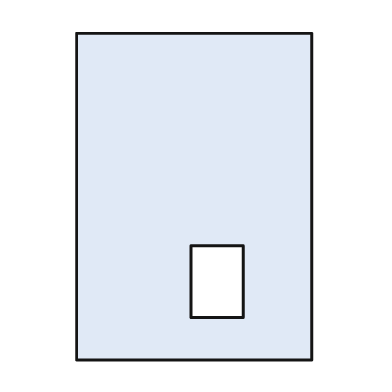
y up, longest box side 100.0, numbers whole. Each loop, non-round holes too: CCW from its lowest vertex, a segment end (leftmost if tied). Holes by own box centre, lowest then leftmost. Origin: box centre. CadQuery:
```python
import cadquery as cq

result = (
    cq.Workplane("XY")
    .moveTo(-36.0, -50.0)
    .lineTo(36.0, -50.0)
    .lineTo(36.0, 50.0)
    .lineTo(-36.0, 50.0)
    .close()
    .moveTo(-1.0, -37.0)
    .lineTo(15.0, -37.0)
    .lineTo(15.0, -15.0)
    .lineTo(-1.0, -15.0)
    .close()
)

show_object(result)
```